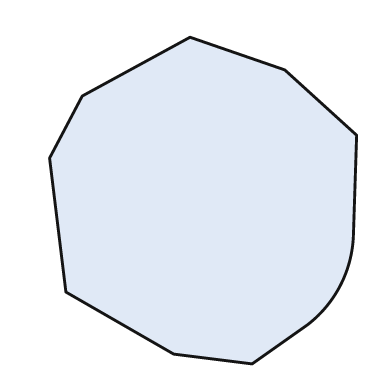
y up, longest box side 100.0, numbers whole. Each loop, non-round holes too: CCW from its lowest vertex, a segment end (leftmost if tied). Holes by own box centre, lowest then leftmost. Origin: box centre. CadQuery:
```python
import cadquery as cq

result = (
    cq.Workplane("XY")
    .moveTo(15.0, -50.0)
    .lineTo(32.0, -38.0)
    .threePointArc((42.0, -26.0), (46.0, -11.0))
    .lineTo(47.0, 20.0)
    .lineTo(25.0, 40.0)
    .lineTo(-4.0, 50.0)
    .lineTo(-37.0, 32.0)
    .lineTo(-47.0, 13.0)
    .lineTo(-42.0, -28.0)
    .lineTo(-9.0, -47.0)
    .close()
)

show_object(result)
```